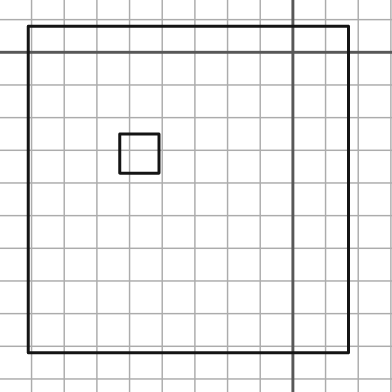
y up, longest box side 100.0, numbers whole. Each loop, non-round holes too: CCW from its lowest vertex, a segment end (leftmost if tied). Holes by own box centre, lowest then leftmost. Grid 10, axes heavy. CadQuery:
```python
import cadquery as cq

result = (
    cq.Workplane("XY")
    .moveTo(-81.0, -92.0)
    .lineTo(17.0, -92.0)
    .lineTo(17.0, 8.0)
    .lineTo(-81.0, 8.0)
    .close()
    .moveTo(-53.0, -37.0)
    .lineTo(-41.0, -37.0)
    .lineTo(-41.0, -25.0)
    .lineTo(-53.0, -25.0)
    .close()
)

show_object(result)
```